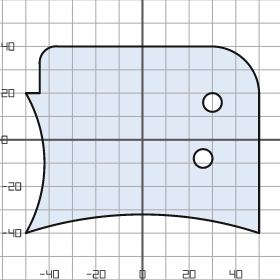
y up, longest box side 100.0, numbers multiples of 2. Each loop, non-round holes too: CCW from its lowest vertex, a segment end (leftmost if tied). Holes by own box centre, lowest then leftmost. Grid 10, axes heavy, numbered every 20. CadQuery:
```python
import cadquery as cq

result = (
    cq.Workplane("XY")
    .moveTo(-50.0, -40.0)
    .threePointArc((0.0, -32.0), (50.0, -40.0))
    .lineTo(50.0, 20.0)
    .threePointArc((44.0, 34.0), (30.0, 40.0))
    .lineTo(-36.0, 40.0)
    .threePointArc((-42.0, 38.0), (-44.0, 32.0))
    .lineTo(-44.0, 20.0)
    .lineTo(-50.0, 20.0)
    .threePointArc((-42.0, -10.0), (-50.0, -40.0))
    .close()
    .moveTo(26.0, -8.0)
    .circle(4.0)
    .moveTo(30.0, 16.0)
    .circle(4.0)
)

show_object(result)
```